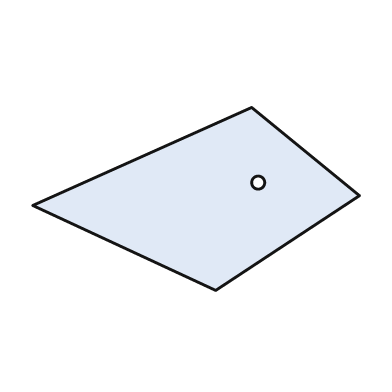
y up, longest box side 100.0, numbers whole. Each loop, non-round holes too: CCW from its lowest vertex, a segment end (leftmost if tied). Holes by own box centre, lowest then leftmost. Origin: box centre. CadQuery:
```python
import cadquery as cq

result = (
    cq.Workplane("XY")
    .moveTo(6.0, -28.0)
    .lineTo(50.0, 1.0)
    .lineTo(17.0, 28.0)
    .lineTo(-50.0, -2.0)
    .close()
    .moveTo(19.0, 5.0)
    .circle(2.0)
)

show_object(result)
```